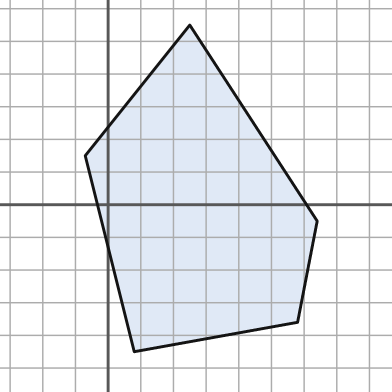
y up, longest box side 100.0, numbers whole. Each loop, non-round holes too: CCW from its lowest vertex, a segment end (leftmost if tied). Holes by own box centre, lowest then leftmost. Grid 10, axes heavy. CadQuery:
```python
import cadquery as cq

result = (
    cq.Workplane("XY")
    .moveTo(8.0, -45.0)
    .lineTo(58.0, -36.0)
    .lineTo(64.0, -5.0)
    .lineTo(25.0, 55.0)
    .lineTo(-7.0, 15.0)
    .close()
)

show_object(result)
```